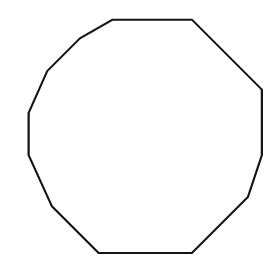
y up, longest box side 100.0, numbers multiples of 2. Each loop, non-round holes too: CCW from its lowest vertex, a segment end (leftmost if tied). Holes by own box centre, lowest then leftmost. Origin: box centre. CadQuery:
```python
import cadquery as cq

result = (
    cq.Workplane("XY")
    .moveTo(-20.0, -50.0)
    .lineTo(20.0, -50.0)
    .lineTo(44.0, -26.0)
    .lineTo(50.0, -8.0)
    .lineTo(50.0, 20.0)
    .lineTo(20.0, 50.0)
    .lineTo(-14.0, 50.0)
    .lineTo(-28.0, 42.0)
    .lineTo(-42.0, 28.0)
    .lineTo(-50.0, 10.0)
    .lineTo(-50.0, -8.0)
    .lineTo(-40.0, -30.0)
    .close()
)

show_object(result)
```